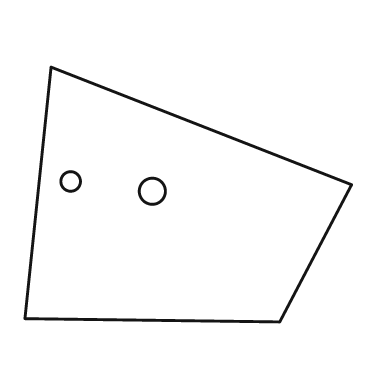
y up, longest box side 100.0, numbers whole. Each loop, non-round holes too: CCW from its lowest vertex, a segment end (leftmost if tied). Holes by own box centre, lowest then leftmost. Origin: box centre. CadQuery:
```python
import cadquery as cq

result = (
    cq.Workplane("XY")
    .moveTo(28.0, -39.0)
    .lineTo(50.0, 3.0)
    .lineTo(-42.0, 39.0)
    .lineTo(-50.0, -38.0)
    .close()
    .moveTo(-11.0, 1.0)
    .circle(4.0)
    .moveTo(-36.0, 4.0)
    .circle(3.0)
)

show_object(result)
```